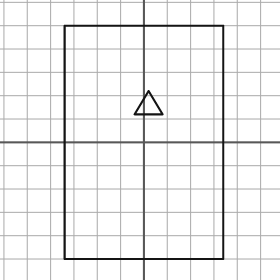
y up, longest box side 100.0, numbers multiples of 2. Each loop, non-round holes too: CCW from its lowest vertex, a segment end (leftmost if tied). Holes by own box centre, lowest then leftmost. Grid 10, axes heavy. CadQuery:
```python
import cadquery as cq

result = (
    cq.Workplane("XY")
    .moveTo(-34.0, -50.0)
    .lineTo(34.0, -50.0)
    .lineTo(34.0, 50.0)
    .lineTo(-34.0, 50.0)
    .close()
    .moveTo(-4.0, 12.0)
    .lineTo(8.0, 12.0)
    .lineTo(2.0, 22.0)
    .close()
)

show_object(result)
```